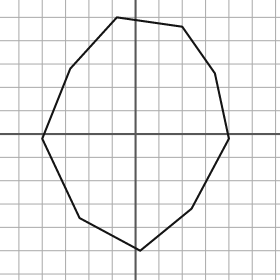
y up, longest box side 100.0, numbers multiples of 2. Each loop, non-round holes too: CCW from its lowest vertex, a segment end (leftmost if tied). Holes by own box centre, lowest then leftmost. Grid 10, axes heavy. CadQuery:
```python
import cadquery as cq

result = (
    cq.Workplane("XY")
    .moveTo(2.0, -50.0)
    .lineTo(24.0, -32.0)
    .lineTo(40.0, -2.0)
    .lineTo(34.0, 26.0)
    .lineTo(20.0, 46.0)
    .lineTo(-8.0, 50.0)
    .lineTo(-28.0, 28.0)
    .lineTo(-40.0, -2.0)
    .lineTo(-24.0, -36.0)
    .close()
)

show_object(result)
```